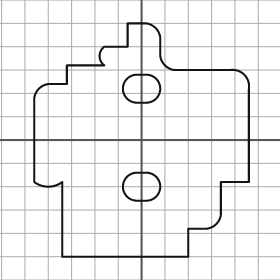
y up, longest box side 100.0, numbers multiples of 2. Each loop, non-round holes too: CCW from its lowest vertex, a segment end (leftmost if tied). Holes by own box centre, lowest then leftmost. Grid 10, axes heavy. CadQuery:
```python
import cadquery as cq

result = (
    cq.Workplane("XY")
    .moveTo(-34.0, -50.0)
    .lineTo(20.0, -50.0)
    .lineTo(20.0, -38.0)
    .lineTo(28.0, -38.0)
    .threePointArc((32.0, -36.0), (34.0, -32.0))
    .lineTo(34.0, -18.0)
    .lineTo(46.0, -18.0)
    .lineTo(46.0, 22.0)
    .threePointArc((44.0, 28.0), (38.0, 30.0))
    .lineTo(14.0, 30.0)
    .threePointArc((10.0, 32.0), (8.0, 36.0))
    .lineTo(8.0, 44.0)
    .threePointArc((6.0, 48.0), (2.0, 50.0))
    .lineTo(-6.0, 50.0)
    .lineTo(-6.0, 40.0)
    .lineTo(-16.0, 40.0)
    .threePointArc((-18.0, 36.0), (-16.0, 32.0))
    .lineTo(-32.0, 32.0)
    .lineTo(-32.0, 24.0)
    .lineTo(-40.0, 24.0)
    .threePointArc((-44.0, 22.0), (-46.0, 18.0))
    .lineTo(-46.0, -18.0)
    .threePointArc((-40.0, -20.0), (-34.0, -18.0))
    .close()
    .moveTo(-2.0, -26.0)
    .lineTo(2.0, -26.0)
    .threePointArc((8.0, -20.0), (2.0, -14.0))
    .lineTo(-2.0, -14.0)
    .threePointArc((-8.0, -20.0), (-2.0, -26.0))
    .close()
    .moveTo(-2.0, 16.0)
    .lineTo(2.0, 16.0)
    .threePointArc((8.0, 22.0), (2.0, 28.0))
    .lineTo(-2.0, 28.0)
    .threePointArc((-8.0, 22.0), (-2.0, 16.0))
    .close()
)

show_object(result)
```